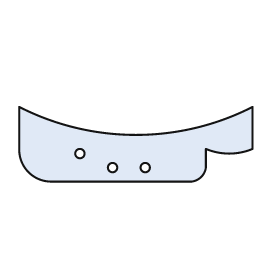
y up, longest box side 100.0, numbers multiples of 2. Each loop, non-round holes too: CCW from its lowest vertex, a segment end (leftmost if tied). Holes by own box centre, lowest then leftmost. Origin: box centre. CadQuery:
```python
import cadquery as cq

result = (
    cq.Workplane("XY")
    .moveTo(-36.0, -16.0)
    .lineTo(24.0, -16.0)
    .threePointArc((28.0, -14.0), (30.0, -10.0))
    .lineTo(30.0, -2.0)
    .threePointArc((40.0, -4.0), (50.0, -2.0))
    .lineTo(50.0, 16.0)
    .threePointArc((0.0, 4.0), (-50.0, 16.0))
    .lineTo(-50.0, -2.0)
    .threePointArc((-46.0, -12.0), (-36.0, -16.0))
    .close()
    .moveTo(-10.0, -10.0)
    .circle(2.0)
    .moveTo(4.0, -10.0)
    .circle(2.0)
    .moveTo(-24.0, -4.0)
    .circle(2.0)
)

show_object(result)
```